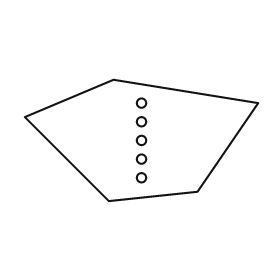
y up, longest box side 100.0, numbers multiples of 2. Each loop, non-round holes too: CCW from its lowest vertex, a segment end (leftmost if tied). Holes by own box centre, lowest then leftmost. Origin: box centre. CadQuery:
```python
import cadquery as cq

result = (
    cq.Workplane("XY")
    .moveTo(-14.0, -26.0)
    .lineTo(24.0, -22.0)
    .lineTo(50.0, 16.0)
    .lineTo(-12.0, 26.0)
    .lineTo(-50.0, 10.0)
    .close()
    .moveTo(0.0, -16.0)
    .circle(2.0)
    .moveTo(0.0, -8.0)
    .circle(2.0)
    .moveTo(0.0, 0.0)
    .circle(2.0)
    .moveTo(0.0, 8.0)
    .circle(2.0)
    .moveTo(0.0, 16.0)
    .circle(2.0)
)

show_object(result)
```